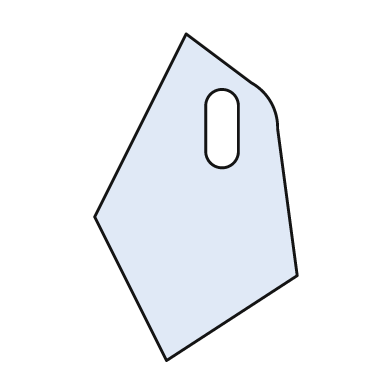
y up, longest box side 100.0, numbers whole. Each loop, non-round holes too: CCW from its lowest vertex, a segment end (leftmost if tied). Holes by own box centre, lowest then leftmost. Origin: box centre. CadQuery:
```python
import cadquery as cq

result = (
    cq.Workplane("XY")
    .moveTo(-9.0, -50.0)
    .lineTo(31.0, -24.0)
    .lineTo(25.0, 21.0)
    .threePointArc((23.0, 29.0), (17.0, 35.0))
    .lineTo(-3.0, 50.0)
    .lineTo(-31.0, -6.0)
    .close()
    .moveTo(3.0, 14.0)
    .threePointArc((8.0, 9.0), (13.0, 14.0))
    .lineTo(13.0, 28.0)
    .threePointArc((8.0, 33.0), (3.0, 28.0))
    .close()
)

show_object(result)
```